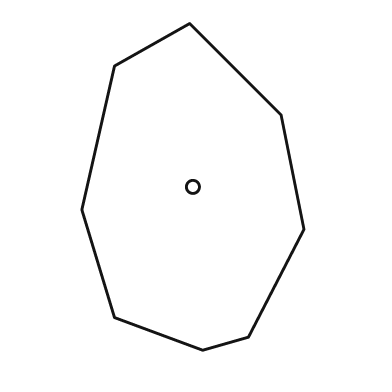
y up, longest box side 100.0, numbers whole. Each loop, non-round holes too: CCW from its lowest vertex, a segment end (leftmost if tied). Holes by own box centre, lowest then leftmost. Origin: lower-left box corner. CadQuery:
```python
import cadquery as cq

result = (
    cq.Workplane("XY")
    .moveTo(37.0, 0.0)
    .lineTo(51.0, 4.0)
    .lineTo(68.0, 37.0)
    .lineTo(61.0, 72.0)
    .lineTo(33.0, 100.0)
    .lineTo(10.0, 87.0)
    .lineTo(0.0, 43.0)
    .lineTo(10.0, 10.0)
    .close()
    .moveTo(34.0, 50.0)
    .circle(2.0)
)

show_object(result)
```